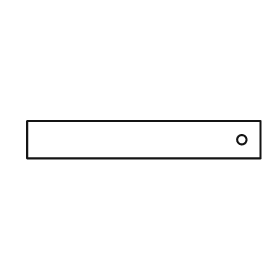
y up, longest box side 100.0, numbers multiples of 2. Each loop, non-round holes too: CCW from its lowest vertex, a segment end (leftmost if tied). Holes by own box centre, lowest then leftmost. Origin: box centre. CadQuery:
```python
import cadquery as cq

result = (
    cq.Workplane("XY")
    .moveTo(-50.0, -8.0)
    .lineTo(50.0, -8.0)
    .lineTo(50.0, 8.0)
    .lineTo(-50.0, 8.0)
    .close()
    .moveTo(42.0, 0.0)
    .circle(2.0)
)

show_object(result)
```